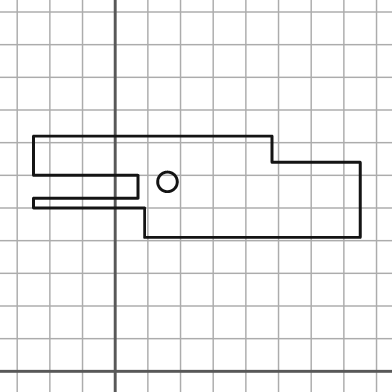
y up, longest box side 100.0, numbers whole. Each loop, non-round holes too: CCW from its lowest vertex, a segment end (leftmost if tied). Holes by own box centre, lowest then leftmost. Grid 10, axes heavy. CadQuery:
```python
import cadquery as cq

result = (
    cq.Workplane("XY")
    .moveTo(9.0, 41.0)
    .lineTo(75.0, 41.0)
    .lineTo(75.0, 64.0)
    .lineTo(48.0, 64.0)
    .lineTo(48.0, 72.0)
    .lineTo(-25.0, 72.0)
    .lineTo(-25.0, 60.0)
    .lineTo(7.0, 60.0)
    .lineTo(7.0, 53.0)
    .lineTo(-25.0, 53.0)
    .lineTo(-25.0, 50.0)
    .lineTo(9.0, 50.0)
    .close()
    .moveTo(16.0, 58.0)
    .circle(3.0)
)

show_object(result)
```